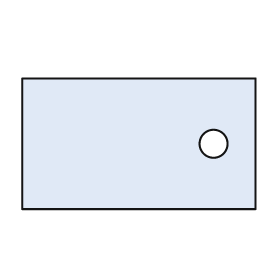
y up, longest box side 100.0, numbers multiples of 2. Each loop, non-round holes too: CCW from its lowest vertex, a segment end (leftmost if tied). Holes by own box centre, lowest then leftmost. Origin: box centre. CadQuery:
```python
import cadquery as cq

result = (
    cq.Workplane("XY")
    .moveTo(-50.0, -28.0)
    .lineTo(50.0, -28.0)
    .lineTo(50.0, 28.0)
    .lineTo(-50.0, 28.0)
    .close()
    .moveTo(32.0, 0.0)
    .circle(6.0)
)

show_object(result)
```